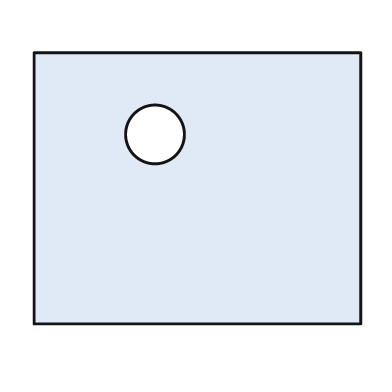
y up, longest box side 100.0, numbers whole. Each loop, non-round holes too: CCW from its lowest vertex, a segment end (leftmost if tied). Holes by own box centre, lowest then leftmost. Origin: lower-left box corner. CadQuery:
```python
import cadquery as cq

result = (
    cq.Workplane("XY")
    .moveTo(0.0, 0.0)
    .lineTo(100.0, 0.0)
    .lineTo(100.0, 83.0)
    .lineTo(0.0, 83.0)
    .close()
    .moveTo(37.0, 58.0)
    .circle(9.0)
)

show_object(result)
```